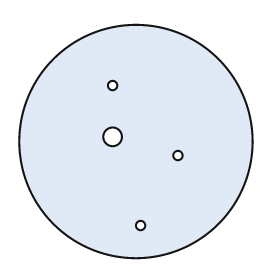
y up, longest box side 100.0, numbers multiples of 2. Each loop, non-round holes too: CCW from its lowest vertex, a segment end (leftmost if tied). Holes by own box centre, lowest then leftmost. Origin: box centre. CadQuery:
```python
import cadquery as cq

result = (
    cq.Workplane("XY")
    .moveTo(0.0, 0.0)
    .circle(50.0)
    .moveTo(2.0, -36.0)
    .circle(2.0)
    .moveTo(18.0, -6.0)
    .circle(2.0)
    .moveTo(-10.0, 2.0)
    .circle(4.0)
    .moveTo(-10.0, 24.0)
    .circle(2.0)
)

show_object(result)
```